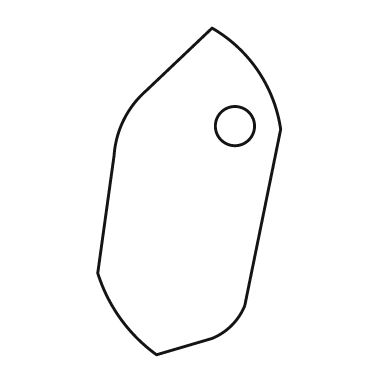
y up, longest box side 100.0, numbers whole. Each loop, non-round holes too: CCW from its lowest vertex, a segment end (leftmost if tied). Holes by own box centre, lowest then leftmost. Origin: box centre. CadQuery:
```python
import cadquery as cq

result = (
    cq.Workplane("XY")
    .moveTo(-10.0, -50.0)
    .lineTo(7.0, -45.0)
    .threePointArc((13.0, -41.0), (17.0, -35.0))
    .lineTo(28.0, 19.0)
    .threePointArc((21.0, 37.0), (7.0, 50.0))
    .lineTo(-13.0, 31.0)
    .threePointArc((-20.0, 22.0), (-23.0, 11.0))
    .lineTo(-28.0, -25.0)
    .threePointArc((-21.0, -39.0), (-10.0, -50.0))
    .close()
    .moveTo(14.0, 20.0)
    .circle(6.0)
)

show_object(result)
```